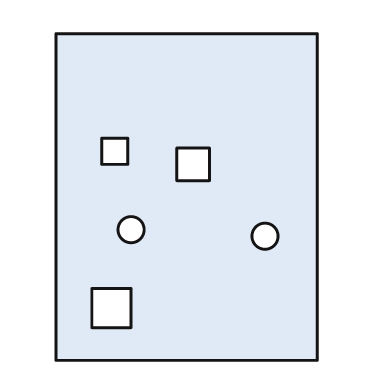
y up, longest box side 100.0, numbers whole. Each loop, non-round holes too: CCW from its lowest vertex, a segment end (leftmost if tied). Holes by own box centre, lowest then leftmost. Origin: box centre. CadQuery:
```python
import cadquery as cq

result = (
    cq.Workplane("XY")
    .moveTo(-40.0, -50.0)
    .lineTo(40.0, -50.0)
    .lineTo(40.0, 50.0)
    .lineTo(-40.0, 50.0)
    .close()
    .moveTo(-29.0, -40.0)
    .lineTo(-17.0, -40.0)
    .lineTo(-17.0, -28.0)
    .lineTo(-29.0, -28.0)
    .close()
    .moveTo(24.0, -12.0)
    .circle(4.0)
    .moveTo(-17.0, -10.0)
    .circle(4.0)
    .moveTo(-3.0, 5.0)
    .lineTo(7.0, 5.0)
    .lineTo(7.0, 15.0)
    .lineTo(-3.0, 15.0)
    .close()
    .moveTo(-26.0, 10.0)
    .lineTo(-18.0, 10.0)
    .lineTo(-18.0, 18.0)
    .lineTo(-26.0, 18.0)
    .close()
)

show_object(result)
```